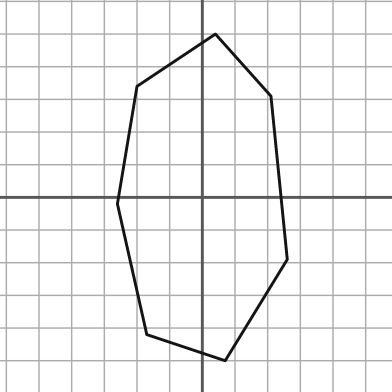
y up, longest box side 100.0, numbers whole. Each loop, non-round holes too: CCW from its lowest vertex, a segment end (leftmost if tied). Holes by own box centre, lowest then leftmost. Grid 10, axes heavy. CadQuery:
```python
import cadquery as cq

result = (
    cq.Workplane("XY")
    .moveTo(7.0, -50.0)
    .lineTo(26.0, -19.0)
    .lineTo(21.0, 31.0)
    .lineTo(4.0, 50.0)
    .lineTo(-20.0, 34.0)
    .lineTo(-26.0, -2.0)
    .lineTo(-17.0, -42.0)
    .close()
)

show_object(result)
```